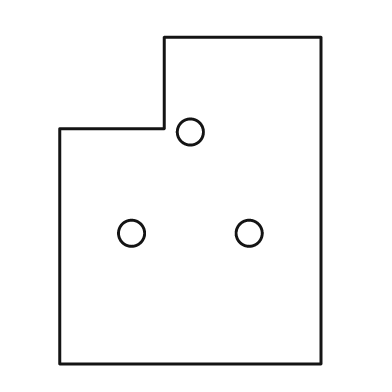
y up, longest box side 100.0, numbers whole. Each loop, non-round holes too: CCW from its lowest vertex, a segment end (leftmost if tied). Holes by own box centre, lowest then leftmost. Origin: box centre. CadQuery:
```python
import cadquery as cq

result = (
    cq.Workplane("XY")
    .moveTo(-40.0, -50.0)
    .lineTo(40.0, -50.0)
    .lineTo(40.0, 50.0)
    .lineTo(-8.0, 50.0)
    .lineTo(-8.0, 22.0)
    .lineTo(-40.0, 22.0)
    .close()
    .moveTo(-18.0, -10.0)
    .circle(4.0)
    .moveTo(18.0, -10.0)
    .circle(4.0)
    .moveTo(0.0, 21.0)
    .circle(4.0)
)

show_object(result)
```